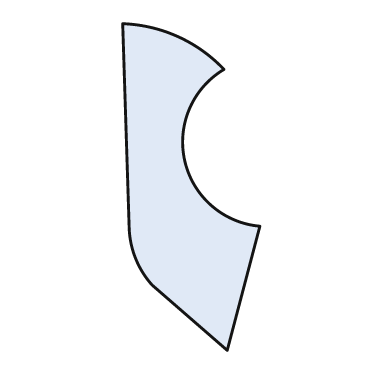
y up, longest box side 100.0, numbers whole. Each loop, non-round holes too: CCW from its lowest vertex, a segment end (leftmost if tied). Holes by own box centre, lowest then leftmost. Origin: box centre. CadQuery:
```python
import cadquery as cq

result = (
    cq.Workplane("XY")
    .moveTo(11.0, -50.0)
    .lineTo(21.0, -12.0)
    .threePointArc((-2.0, 8.0), (10.0, 36.0))
    .threePointArc((-4.0, 46.0), (-21.0, 50.0))
    .lineTo(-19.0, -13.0)
    .threePointArc((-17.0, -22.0), (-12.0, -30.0))
    .close()
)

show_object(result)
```